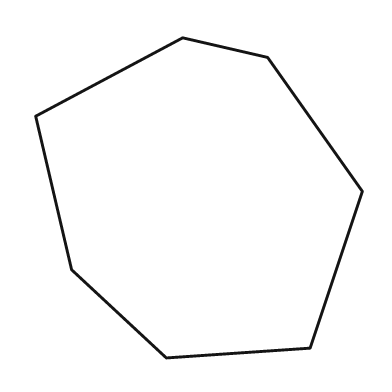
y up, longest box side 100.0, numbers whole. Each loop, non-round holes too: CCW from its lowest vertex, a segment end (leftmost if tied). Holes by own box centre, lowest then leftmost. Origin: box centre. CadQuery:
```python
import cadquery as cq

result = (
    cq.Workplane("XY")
    .moveTo(-10.0, -49.0)
    .lineTo(34.0, -46.0)
    .lineTo(50.0, 2.0)
    .lineTo(21.0, 43.0)
    .lineTo(-5.0, 49.0)
    .lineTo(-50.0, 25.0)
    .lineTo(-39.0, -22.0)
    .close()
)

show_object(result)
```